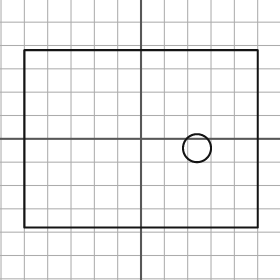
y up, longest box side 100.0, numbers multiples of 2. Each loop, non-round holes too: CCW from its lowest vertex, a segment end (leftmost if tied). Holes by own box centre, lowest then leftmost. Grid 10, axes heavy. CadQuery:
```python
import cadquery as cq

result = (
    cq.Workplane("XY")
    .moveTo(-50.0, -38.0)
    .lineTo(50.0, -38.0)
    .lineTo(50.0, 38.0)
    .lineTo(-50.0, 38.0)
    .close()
    .moveTo(24.0, -4.0)
    .circle(6.0)
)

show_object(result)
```